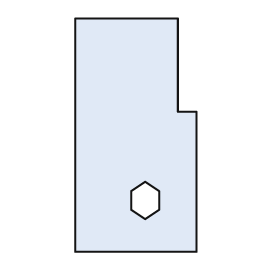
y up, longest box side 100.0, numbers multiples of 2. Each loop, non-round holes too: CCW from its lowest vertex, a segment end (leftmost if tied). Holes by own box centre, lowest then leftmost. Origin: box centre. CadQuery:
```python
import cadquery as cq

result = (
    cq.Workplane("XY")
    .moveTo(-26.0, -50.0)
    .lineTo(26.0, -50.0)
    .lineTo(26.0, 10.0)
    .lineTo(18.0, 10.0)
    .lineTo(18.0, 50.0)
    .lineTo(-26.0, 50.0)
    .close()
    .moveTo(4.0, -36.0)
    .lineTo(10.0, -32.0)
    .lineTo(10.0, -24.0)
    .lineTo(4.0, -20.0)
    .lineTo(-2.0, -24.0)
    .lineTo(-2.0, -32.0)
    .close()
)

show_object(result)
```